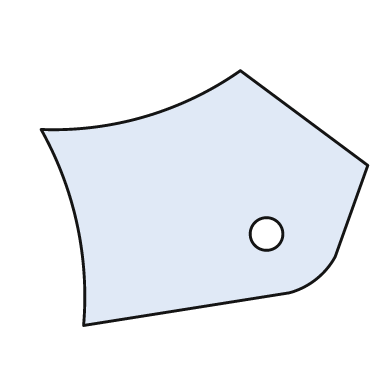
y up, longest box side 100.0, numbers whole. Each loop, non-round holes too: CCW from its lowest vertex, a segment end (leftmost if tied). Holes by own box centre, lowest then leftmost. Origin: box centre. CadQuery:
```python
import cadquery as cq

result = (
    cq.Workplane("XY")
    .moveTo(-37.0, -39.0)
    .lineTo(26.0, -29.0)
    .threePointArc((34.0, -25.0), (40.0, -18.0))
    .lineTo(50.0, 10.0)
    .lineTo(11.0, 39.0)
    .threePointArc((-18.0, 25.0), (-50.0, 21.0))
    .threePointArc((-39.0, -8.0), (-37.0, -39.0))
    .close()
    .moveTo(19.0, -11.0)
    .circle(5.0)
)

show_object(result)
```